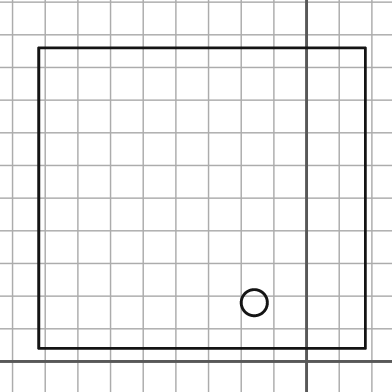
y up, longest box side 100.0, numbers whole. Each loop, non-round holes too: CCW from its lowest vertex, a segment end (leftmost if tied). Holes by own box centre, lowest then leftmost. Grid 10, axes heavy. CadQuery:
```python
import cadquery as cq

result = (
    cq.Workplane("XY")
    .moveTo(-82.0, 4.0)
    .lineTo(18.0, 4.0)
    .lineTo(18.0, 96.0)
    .lineTo(-82.0, 96.0)
    .close()
    .moveTo(-16.0, 18.0)
    .circle(4.0)
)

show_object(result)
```